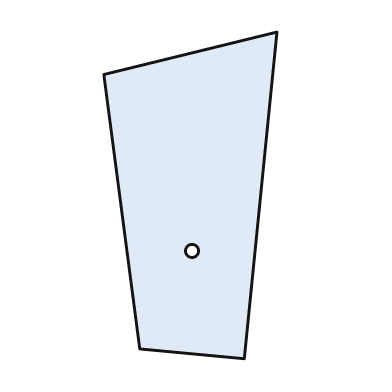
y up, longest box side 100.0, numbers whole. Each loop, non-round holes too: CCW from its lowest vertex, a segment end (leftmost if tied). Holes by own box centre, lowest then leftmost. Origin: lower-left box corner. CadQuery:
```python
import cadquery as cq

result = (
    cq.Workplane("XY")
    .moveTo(43.0, 0.0)
    .lineTo(53.0, 100.0)
    .lineTo(0.0, 87.0)
    .lineTo(11.0, 3.0)
    .close()
    .moveTo(27.0, 33.0)
    .circle(2.0)
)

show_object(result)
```